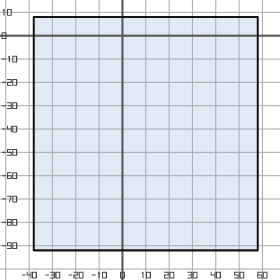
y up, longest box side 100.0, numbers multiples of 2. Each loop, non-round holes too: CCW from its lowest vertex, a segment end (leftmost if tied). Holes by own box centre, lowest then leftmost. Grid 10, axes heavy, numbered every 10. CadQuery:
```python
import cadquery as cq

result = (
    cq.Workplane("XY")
    .moveTo(-38.0, -92.0)
    .lineTo(58.0, -92.0)
    .lineTo(58.0, 8.0)
    .lineTo(-38.0, 8.0)
    .close()
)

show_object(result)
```